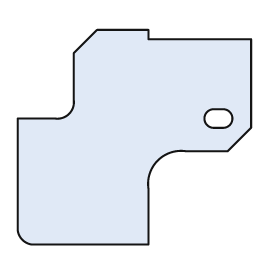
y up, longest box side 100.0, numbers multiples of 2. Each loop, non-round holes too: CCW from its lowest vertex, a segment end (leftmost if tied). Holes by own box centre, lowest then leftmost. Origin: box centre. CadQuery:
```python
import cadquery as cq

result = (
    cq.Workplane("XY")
    .moveTo(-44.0, -46.0)
    .lineTo(6.0, -46.0)
    .lineTo(6.0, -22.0)
    .threePointArc((10.0, -10.0), (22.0, -6.0))
    .lineTo(40.0, -6.0)
    .lineTo(50.0, 4.0)
    .lineTo(50.0, 42.0)
    .lineTo(6.0, 42.0)
    .lineTo(6.0, 46.0)
    .lineTo(-16.0, 46.0)
    .lineTo(-26.0, 36.0)
    .lineTo(-26.0, 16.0)
    .threePointArc((-28.0, 10.0), (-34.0, 8.0))
    .lineTo(-50.0, 8.0)
    .lineTo(-50.0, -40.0)
    .threePointArc((-48.0, -44.0), (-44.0, -46.0))
    .close()
    .moveTo(34.0, 4.0)
    .lineTo(38.0, 4.0)
    .threePointArc((42.0, 8.0), (38.0, 12.0))
    .lineTo(34.0, 12.0)
    .threePointArc((30.0, 8.0), (34.0, 4.0))
    .close()
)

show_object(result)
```